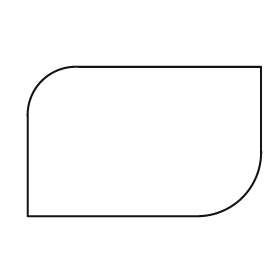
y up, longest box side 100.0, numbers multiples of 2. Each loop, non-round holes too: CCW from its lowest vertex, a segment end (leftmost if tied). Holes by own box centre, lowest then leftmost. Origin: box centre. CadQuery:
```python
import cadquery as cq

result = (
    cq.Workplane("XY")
    .moveTo(-50.0, -32.0)
    .lineTo(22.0, -32.0)
    .threePointArc((42.0, -24.0), (50.0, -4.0))
    .lineTo(50.0, 32.0)
    .lineTo(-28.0, 32.0)
    .threePointArc((-44.0, 26.0), (-50.0, 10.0))
    .close()
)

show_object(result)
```